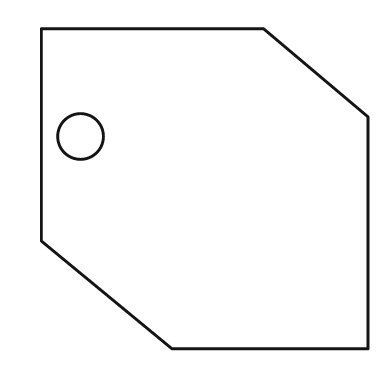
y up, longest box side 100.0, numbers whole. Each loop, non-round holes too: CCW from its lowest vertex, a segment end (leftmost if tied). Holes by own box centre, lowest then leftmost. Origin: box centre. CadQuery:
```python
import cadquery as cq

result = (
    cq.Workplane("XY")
    .moveTo(-10.0, -49.0)
    .lineTo(50.0, -49.0)
    .lineTo(50.0, 22.0)
    .lineTo(18.0, 49.0)
    .lineTo(-50.0, 49.0)
    .lineTo(-50.0, -16.0)
    .close()
    .moveTo(-38.0, 16.0)
    .circle(7.0)
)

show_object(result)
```